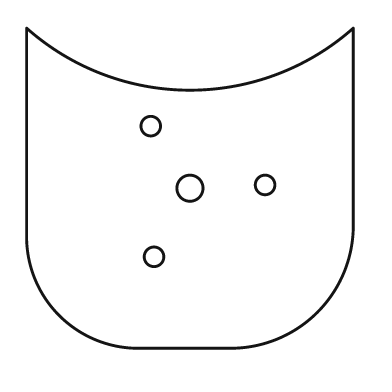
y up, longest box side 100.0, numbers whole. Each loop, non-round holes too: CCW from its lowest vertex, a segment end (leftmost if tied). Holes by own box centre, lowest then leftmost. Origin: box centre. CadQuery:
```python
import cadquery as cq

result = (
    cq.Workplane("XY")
    .moveTo(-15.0, -49.0)
    .lineTo(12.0, -49.0)
    .threePointArc((39.0, -38.0), (50.0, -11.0))
    .lineTo(50.0, 49.0)
    .threePointArc((0.0, 30.0), (-50.0, 49.0))
    .lineTo(-50.0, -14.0)
    .threePointArc((-40.0, -39.0), (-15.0, -49.0))
    .close()
    .moveTo(-11.0, -21.0)
    .circle(3.0)
    .moveTo(0.0, 0.0)
    .circle(4.0)
    .moveTo(23.0, 1.0)
    .circle(3.0)
    .moveTo(-12.0, 19.0)
    .circle(3.0)
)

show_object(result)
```